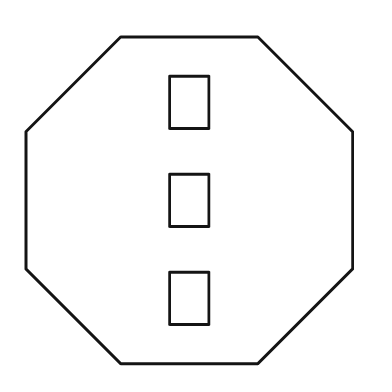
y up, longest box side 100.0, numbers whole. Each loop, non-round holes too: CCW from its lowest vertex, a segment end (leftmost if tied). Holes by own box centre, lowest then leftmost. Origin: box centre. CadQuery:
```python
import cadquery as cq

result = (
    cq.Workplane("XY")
    .moveTo(-21.0, -50.0)
    .lineTo(21.0, -50.0)
    .lineTo(50.0, -21.0)
    .lineTo(50.0, 21.0)
    .lineTo(21.0, 50.0)
    .lineTo(-21.0, 50.0)
    .lineTo(-50.0, 21.0)
    .lineTo(-50.0, -21.0)
    .close()
    .moveTo(-6.0, -38.0)
    .lineTo(6.0, -38.0)
    .lineTo(6.0, -22.0)
    .lineTo(-6.0, -22.0)
    .close()
    .moveTo(-6.0, -8.0)
    .lineTo(6.0, -8.0)
    .lineTo(6.0, 8.0)
    .lineTo(-6.0, 8.0)
    .close()
    .moveTo(-6.0, 22.0)
    .lineTo(6.0, 22.0)
    .lineTo(6.0, 38.0)
    .lineTo(-6.0, 38.0)
    .close()
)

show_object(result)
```